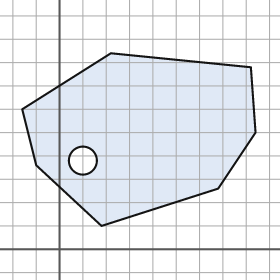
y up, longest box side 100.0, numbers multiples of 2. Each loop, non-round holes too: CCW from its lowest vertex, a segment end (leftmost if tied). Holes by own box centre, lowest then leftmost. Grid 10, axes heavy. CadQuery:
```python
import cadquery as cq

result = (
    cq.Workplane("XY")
    .moveTo(18.0, 10.0)
    .lineTo(68.0, 26.0)
    .lineTo(84.0, 50.0)
    .lineTo(82.0, 78.0)
    .lineTo(22.0, 84.0)
    .lineTo(-16.0, 60.0)
    .lineTo(-10.0, 36.0)
    .close()
    .moveTo(10.0, 38.0)
    .circle(6.0)
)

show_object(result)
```